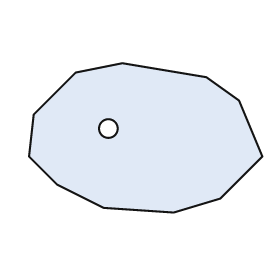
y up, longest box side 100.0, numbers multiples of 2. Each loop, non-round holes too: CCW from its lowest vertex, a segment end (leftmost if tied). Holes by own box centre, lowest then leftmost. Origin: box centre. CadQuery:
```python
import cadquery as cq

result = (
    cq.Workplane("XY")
    .moveTo(12.0, -32.0)
    .lineTo(32.0, -26.0)
    .lineTo(50.0, -8.0)
    .lineTo(40.0, 16.0)
    .lineTo(26.0, 26.0)
    .lineTo(-10.0, 32.0)
    .lineTo(-30.0, 28.0)
    .lineTo(-48.0, 10.0)
    .lineTo(-50.0, -8.0)
    .lineTo(-38.0, -20.0)
    .lineTo(-18.0, -30.0)
    .close()
    .moveTo(-16.0, 4.0)
    .circle(4.0)
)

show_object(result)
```